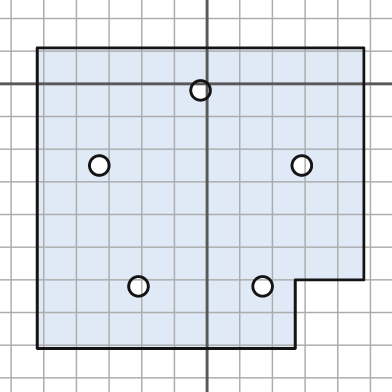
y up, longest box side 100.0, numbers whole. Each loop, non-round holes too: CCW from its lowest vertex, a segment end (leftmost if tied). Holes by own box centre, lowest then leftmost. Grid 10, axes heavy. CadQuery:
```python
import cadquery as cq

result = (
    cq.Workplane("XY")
    .moveTo(-52.0, -81.0)
    .lineTo(27.0, -81.0)
    .lineTo(27.0, -60.0)
    .lineTo(48.0, -60.0)
    .lineTo(48.0, 11.0)
    .lineTo(-52.0, 11.0)
    .close()
    .moveTo(-21.0, -62.0)
    .circle(3.0)
    .moveTo(17.0, -62.0)
    .circle(3.0)
    .moveTo(-33.0, -25.0)
    .circle(3.0)
    .moveTo(29.0, -25.0)
    .circle(3.0)
    .moveTo(-2.0, -2.0)
    .circle(3.0)
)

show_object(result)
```